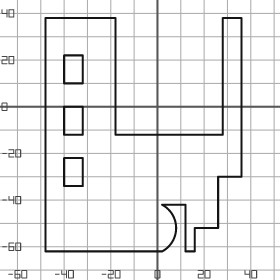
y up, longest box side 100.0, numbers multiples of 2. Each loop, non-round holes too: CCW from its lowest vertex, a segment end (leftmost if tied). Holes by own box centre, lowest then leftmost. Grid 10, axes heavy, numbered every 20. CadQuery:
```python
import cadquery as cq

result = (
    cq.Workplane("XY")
    .moveTo(-48.0, -62.0)
    .lineTo(2.0, -62.0)
    .threePointArc((8.0, -52.0), (2.0, -42.0))
    .lineTo(12.0, -42.0)
    .lineTo(12.0, -62.0)
    .lineTo(16.0, -62.0)
    .lineTo(16.0, -52.0)
    .lineTo(26.0, -52.0)
    .lineTo(26.0, -30.0)
    .lineTo(36.0, -30.0)
    .lineTo(36.0, 38.0)
    .lineTo(28.0, 38.0)
    .lineTo(28.0, -12.0)
    .lineTo(-18.0, -12.0)
    .lineTo(-18.0, 38.0)
    .lineTo(-48.0, 38.0)
    .close()
    .moveTo(-40.0, -34.0)
    .lineTo(-32.0, -34.0)
    .lineTo(-32.0, -22.0)
    .lineTo(-40.0, -22.0)
    .close()
    .moveTo(-40.0, -12.0)
    .lineTo(-32.0, -12.0)
    .lineTo(-32.0, 0.0)
    .lineTo(-40.0, 0.0)
    .close()
    .moveTo(-40.0, 10.0)
    .lineTo(-32.0, 10.0)
    .lineTo(-32.0, 22.0)
    .lineTo(-40.0, 22.0)
    .close()
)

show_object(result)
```